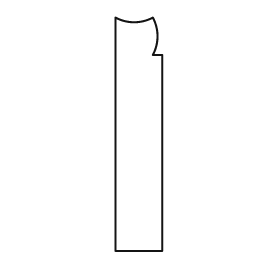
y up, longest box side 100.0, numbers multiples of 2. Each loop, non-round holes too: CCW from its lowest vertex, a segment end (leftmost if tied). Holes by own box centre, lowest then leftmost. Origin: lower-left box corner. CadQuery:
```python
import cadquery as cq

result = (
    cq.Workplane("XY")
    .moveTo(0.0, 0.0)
    .lineTo(20.0, 0.0)
    .lineTo(20.0, 84.0)
    .lineTo(16.0, 84.0)
    .threePointArc((18.0, 92.0), (16.0, 100.0))
    .threePointArc((8.0, 98.0), (0.0, 100.0))
    .close()
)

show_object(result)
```